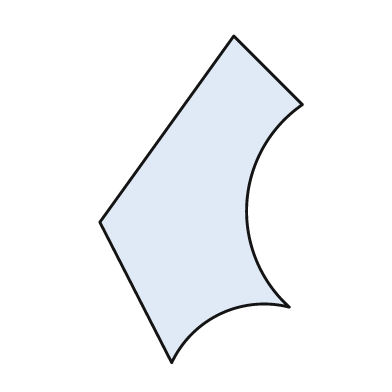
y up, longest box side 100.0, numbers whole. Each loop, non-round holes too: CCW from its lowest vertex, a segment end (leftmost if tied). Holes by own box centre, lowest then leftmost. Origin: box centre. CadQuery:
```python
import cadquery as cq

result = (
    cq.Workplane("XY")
    .moveTo(-9.0, -50.0)
    .threePointArc((6.0, -35.0), (27.0, -33.0))
    .threePointArc((14.0, -1.0), (31.0, 29.0))
    .lineTo(10.0, 50.0)
    .lineTo(-31.0, -7.0)
    .close()
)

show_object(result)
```